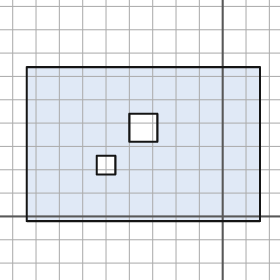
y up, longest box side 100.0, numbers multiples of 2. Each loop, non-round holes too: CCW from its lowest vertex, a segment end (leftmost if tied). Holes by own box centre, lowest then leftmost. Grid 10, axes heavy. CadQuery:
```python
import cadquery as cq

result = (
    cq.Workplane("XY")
    .moveTo(-84.0, -2.0)
    .lineTo(16.0, -2.0)
    .lineTo(16.0, 64.0)
    .lineTo(-84.0, 64.0)
    .close()
    .moveTo(-54.0, 18.0)
    .lineTo(-46.0, 18.0)
    .lineTo(-46.0, 26.0)
    .lineTo(-54.0, 26.0)
    .close()
    .moveTo(-40.0, 32.0)
    .lineTo(-28.0, 32.0)
    .lineTo(-28.0, 44.0)
    .lineTo(-40.0, 44.0)
    .close()
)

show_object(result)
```